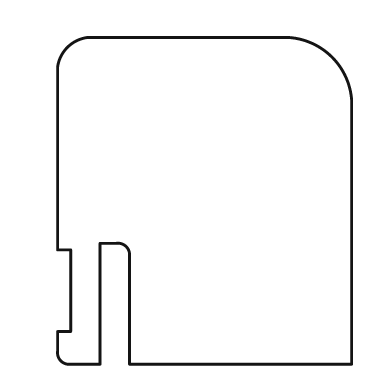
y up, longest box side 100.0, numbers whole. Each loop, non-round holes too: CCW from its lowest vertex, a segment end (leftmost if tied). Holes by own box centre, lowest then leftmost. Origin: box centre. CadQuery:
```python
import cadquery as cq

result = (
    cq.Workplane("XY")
    .moveTo(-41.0, -50.0)
    .lineTo(-32.0, -50.0)
    .lineTo(-32.0, -13.0)
    .lineTo(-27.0, -13.0)
    .threePointArc((-24.0, -14.0), (-23.0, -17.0))
    .lineTo(-23.0, -50.0)
    .lineTo(45.0, -50.0)
    .lineTo(45.0, 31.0)
    .threePointArc((39.0, 44.0), (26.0, 50.0))
    .lineTo(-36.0, 50.0)
    .threePointArc((-42.0, 47.0), (-45.0, 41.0))
    .lineTo(-45.0, -15.0)
    .lineTo(-41.0, -15.0)
    .lineTo(-41.0, -40.0)
    .lineTo(-45.0, -40.0)
    .lineTo(-45.0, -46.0)
    .threePointArc((-44.0, -49.0), (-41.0, -50.0))
    .close()
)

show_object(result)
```